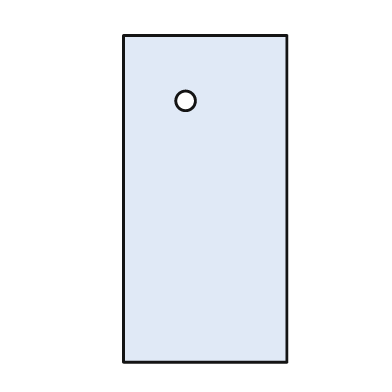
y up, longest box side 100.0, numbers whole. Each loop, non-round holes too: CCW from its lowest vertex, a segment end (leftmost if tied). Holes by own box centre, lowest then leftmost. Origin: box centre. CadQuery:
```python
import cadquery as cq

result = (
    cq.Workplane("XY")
    .moveTo(-25.0, -50.0)
    .lineTo(25.0, -50.0)
    .lineTo(25.0, 50.0)
    .lineTo(-25.0, 50.0)
    .close()
    .moveTo(-6.0, 30.0)
    .circle(3.0)
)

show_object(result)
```